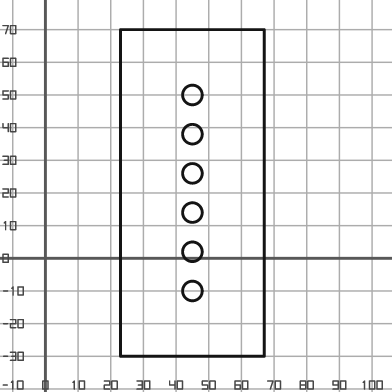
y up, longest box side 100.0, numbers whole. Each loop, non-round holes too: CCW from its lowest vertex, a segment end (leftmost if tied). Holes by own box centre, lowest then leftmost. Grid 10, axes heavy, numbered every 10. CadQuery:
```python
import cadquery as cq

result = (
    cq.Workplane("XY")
    .moveTo(23.0, -30.0)
    .lineTo(67.0, -30.0)
    .lineTo(67.0, 70.0)
    .lineTo(23.0, 70.0)
    .close()
    .moveTo(45.0, -10.0)
    .circle(3.0)
    .moveTo(45.0, 2.0)
    .circle(3.0)
    .moveTo(45.0, 14.0)
    .circle(3.0)
    .moveTo(45.0, 26.0)
    .circle(3.0)
    .moveTo(45.0, 38.0)
    .circle(3.0)
    .moveTo(45.0, 50.0)
    .circle(3.0)
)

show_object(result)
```